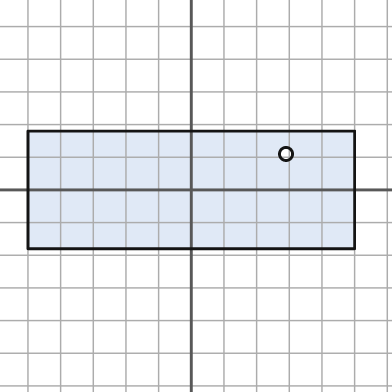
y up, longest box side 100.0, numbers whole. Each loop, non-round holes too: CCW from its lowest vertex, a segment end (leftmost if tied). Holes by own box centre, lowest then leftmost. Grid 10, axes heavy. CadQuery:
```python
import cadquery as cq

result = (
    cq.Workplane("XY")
    .moveTo(-50.0, -18.0)
    .lineTo(50.0, -18.0)
    .lineTo(50.0, 18.0)
    .lineTo(-50.0, 18.0)
    .close()
    .moveTo(29.0, 11.0)
    .circle(2.0)
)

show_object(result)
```